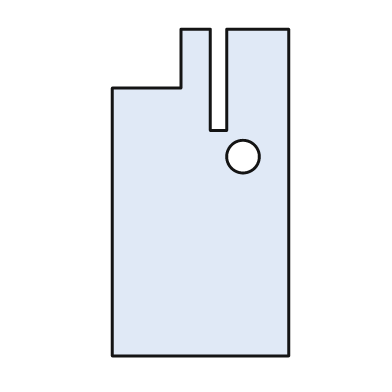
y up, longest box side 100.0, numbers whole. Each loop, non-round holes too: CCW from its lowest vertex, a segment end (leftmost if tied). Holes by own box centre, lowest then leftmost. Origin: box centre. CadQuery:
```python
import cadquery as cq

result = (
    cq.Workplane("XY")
    .moveTo(-27.0, -50.0)
    .lineTo(27.0, -50.0)
    .lineTo(27.0, 50.0)
    .lineTo(8.0, 50.0)
    .lineTo(8.0, 19.0)
    .lineTo(3.0, 19.0)
    .lineTo(3.0, 50.0)
    .lineTo(-6.0, 50.0)
    .lineTo(-6.0, 32.0)
    .lineTo(-27.0, 32.0)
    .close()
    .moveTo(13.0, 11.0)
    .circle(5.0)
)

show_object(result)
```